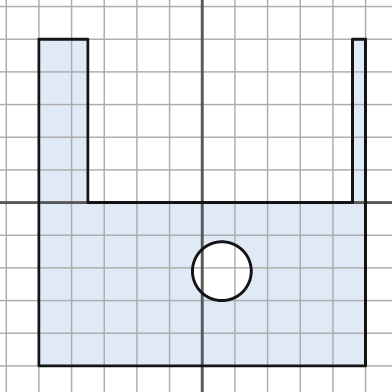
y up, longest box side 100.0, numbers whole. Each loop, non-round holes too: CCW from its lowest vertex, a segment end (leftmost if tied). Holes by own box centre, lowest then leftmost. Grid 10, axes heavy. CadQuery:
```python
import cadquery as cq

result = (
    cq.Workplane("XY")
    .moveTo(-50.0, -50.0)
    .lineTo(50.0, -50.0)
    .lineTo(50.0, 50.0)
    .lineTo(46.0, 50.0)
    .lineTo(46.0, 0.0)
    .lineTo(-35.0, 0.0)
    .lineTo(-35.0, 50.0)
    .lineTo(-50.0, 50.0)
    .close()
    .moveTo(6.0, -21.0)
    .circle(9.0)
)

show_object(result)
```